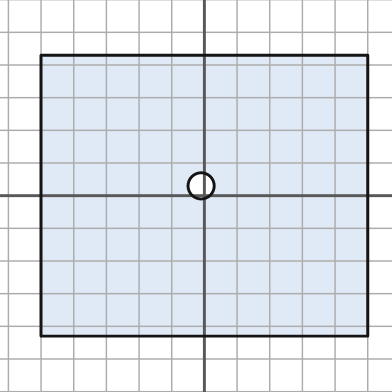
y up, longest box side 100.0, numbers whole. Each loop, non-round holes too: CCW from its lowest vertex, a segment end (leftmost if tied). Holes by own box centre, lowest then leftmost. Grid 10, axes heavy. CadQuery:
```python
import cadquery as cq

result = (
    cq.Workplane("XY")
    .moveTo(-50.0, -43.0)
    .lineTo(50.0, -43.0)
    .lineTo(50.0, 43.0)
    .lineTo(-50.0, 43.0)
    .close()
    .moveTo(-1.0, 3.0)
    .circle(4.0)
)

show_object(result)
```